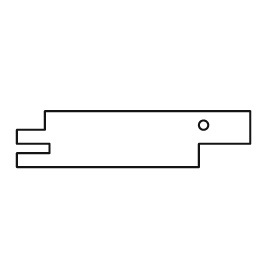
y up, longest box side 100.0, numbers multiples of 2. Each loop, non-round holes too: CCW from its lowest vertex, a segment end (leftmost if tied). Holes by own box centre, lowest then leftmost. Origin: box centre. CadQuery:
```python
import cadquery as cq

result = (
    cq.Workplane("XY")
    .moveTo(-50.0, -12.0)
    .lineTo(28.0, -12.0)
    .lineTo(28.0, -2.0)
    .lineTo(50.0, -2.0)
    .lineTo(50.0, 12.0)
    .lineTo(-38.0, 12.0)
    .lineTo(-38.0, 4.0)
    .lineTo(-50.0, 4.0)
    .lineTo(-50.0, -2.0)
    .lineTo(-36.0, -2.0)
    .lineTo(-36.0, -6.0)
    .lineTo(-50.0, -6.0)
    .close()
    .moveTo(30.0, 6.0)
    .circle(2.0)
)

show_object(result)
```